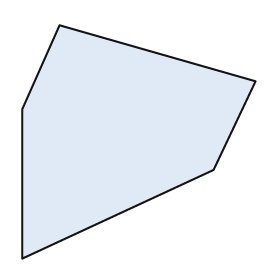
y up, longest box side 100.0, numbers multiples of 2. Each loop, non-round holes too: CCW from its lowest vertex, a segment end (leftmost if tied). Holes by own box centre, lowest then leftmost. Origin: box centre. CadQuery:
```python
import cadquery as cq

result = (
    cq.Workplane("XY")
    .moveTo(-50.0, -50.0)
    .lineTo(32.0, -12.0)
    .lineTo(50.0, 26.0)
    .lineTo(-34.0, 50.0)
    .lineTo(-50.0, 14.0)
    .close()
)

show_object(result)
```